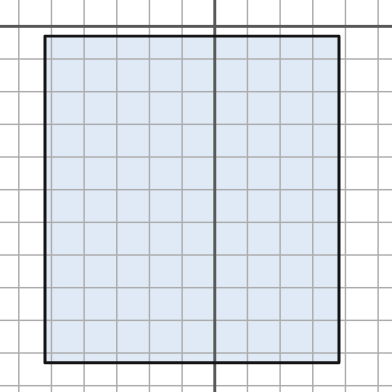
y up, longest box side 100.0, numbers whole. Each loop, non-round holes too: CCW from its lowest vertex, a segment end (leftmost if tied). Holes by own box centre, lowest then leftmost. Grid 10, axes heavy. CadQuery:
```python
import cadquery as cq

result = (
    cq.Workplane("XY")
    .moveTo(-52.0, -103.0)
    .lineTo(38.0, -103.0)
    .lineTo(38.0, -3.0)
    .lineTo(-52.0, -3.0)
    .close()
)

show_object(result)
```